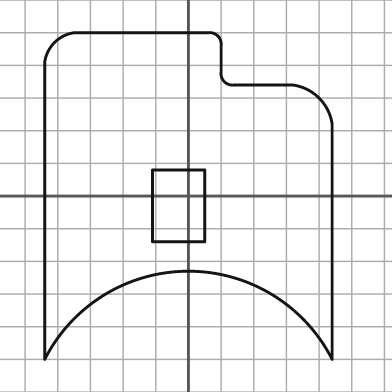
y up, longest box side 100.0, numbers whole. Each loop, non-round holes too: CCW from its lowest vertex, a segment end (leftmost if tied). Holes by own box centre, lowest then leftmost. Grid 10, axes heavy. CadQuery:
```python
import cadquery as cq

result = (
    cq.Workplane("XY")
    .moveTo(-44.0, -50.0)
    .threePointArc((0.0, -23.0), (44.0, -50.0))
    .lineTo(44.0, 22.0)
    .threePointArc((40.0, 30.0), (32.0, 34.0))
    .lineTo(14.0, 34.0)
    .threePointArc((11.0, 35.0), (10.0, 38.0))
    .lineTo(10.0, 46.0)
    .threePointArc((9.0, 49.0), (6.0, 50.0))
    .lineTo(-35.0, 50.0)
    .threePointArc((-41.0, 47.0), (-44.0, 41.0))
    .close()
    .moveTo(-11.0, -14.0)
    .lineTo(5.0, -14.0)
    .lineTo(5.0, 8.0)
    .lineTo(-11.0, 8.0)
    .close()
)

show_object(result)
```